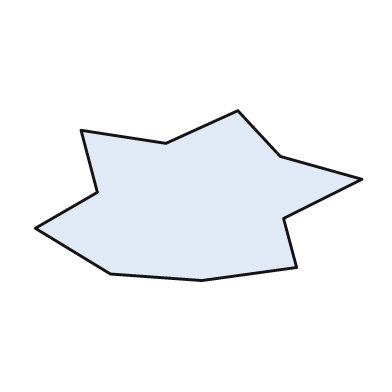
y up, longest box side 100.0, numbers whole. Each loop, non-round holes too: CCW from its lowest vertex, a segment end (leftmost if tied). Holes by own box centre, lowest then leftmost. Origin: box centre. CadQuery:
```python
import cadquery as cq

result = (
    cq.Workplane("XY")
    .moveTo(1.0, -26.0)
    .lineTo(30.0, -22.0)
    .lineTo(26.0, -7.0)
    .lineTo(50.0, 5.0)
    .lineTo(25.0, 12.0)
    .lineTo(12.0, 26.0)
    .lineTo(-10.0, 16.0)
    .lineTo(-36.0, 20.0)
    .lineTo(-31.0, 1.0)
    .lineTo(-50.0, -10.0)
    .lineTo(-27.0, -24.0)
    .close()
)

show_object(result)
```